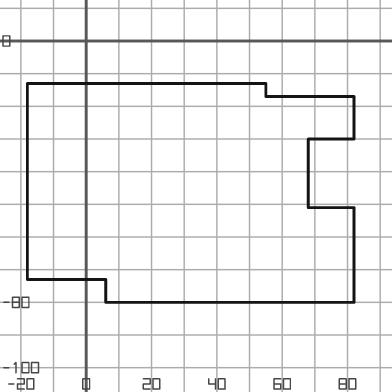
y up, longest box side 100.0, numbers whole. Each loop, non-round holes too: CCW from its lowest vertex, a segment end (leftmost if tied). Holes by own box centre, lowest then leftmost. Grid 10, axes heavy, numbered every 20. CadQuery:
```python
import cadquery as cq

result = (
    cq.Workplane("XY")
    .moveTo(6.0, -80.0)
    .lineTo(82.0, -80.0)
    .lineTo(82.0, -51.0)
    .lineTo(68.0, -51.0)
    .lineTo(68.0, -30.0)
    .lineTo(82.0, -30.0)
    .lineTo(82.0, -17.0)
    .lineTo(55.0, -17.0)
    .lineTo(55.0, -13.0)
    .lineTo(-18.0, -13.0)
    .lineTo(-18.0, -73.0)
    .lineTo(6.0, -73.0)
    .close()
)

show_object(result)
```